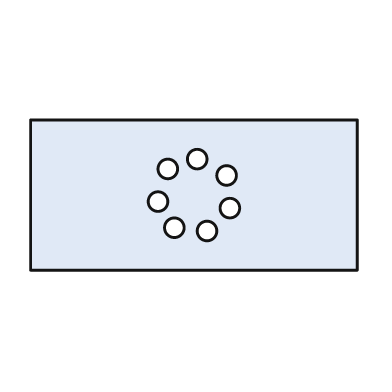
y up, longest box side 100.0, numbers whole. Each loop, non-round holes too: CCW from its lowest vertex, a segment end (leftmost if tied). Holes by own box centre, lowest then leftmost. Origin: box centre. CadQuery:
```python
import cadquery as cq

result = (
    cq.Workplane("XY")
    .moveTo(-50.0, -23.0)
    .lineTo(50.0, -23.0)
    .lineTo(50.0, 23.0)
    .lineTo(-50.0, 23.0)
    .close()
    .moveTo(4.0, -11.0)
    .circle(3.0)
    .moveTo(-6.0, -10.0)
    .circle(3.0)
    .moveTo(11.0, -4.0)
    .circle(3.0)
    .moveTo(-11.0, -2.0)
    .circle(3.0)
    .moveTo(10.0, 6.0)
    .circle(3.0)
    .moveTo(-8.0, 8.0)
    .circle(3.0)
    .moveTo(1.0, 11.0)
    .circle(3.0)
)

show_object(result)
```